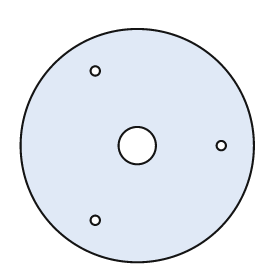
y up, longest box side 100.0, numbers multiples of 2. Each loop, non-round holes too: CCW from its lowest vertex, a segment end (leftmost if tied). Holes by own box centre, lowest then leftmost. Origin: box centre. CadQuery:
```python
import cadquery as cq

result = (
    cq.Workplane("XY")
    .moveTo(0.0, 0.0)
    .circle(50.0)
    .moveTo(-18.0, -32.0)
    .circle(2.0)
    .moveTo(0.0, 0.0)
    .circle(8.0)
    .moveTo(36.0, 0.0)
    .circle(2.0)
    .moveTo(-18.0, 32.0)
    .circle(2.0)
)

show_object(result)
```